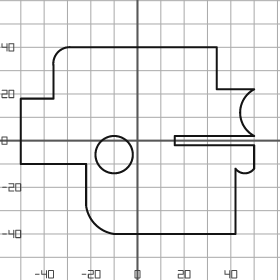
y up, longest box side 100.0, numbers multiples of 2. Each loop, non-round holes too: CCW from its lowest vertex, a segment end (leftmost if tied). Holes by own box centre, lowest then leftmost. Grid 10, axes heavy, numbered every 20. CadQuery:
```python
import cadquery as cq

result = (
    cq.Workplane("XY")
    .moveTo(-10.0, -40.0)
    .lineTo(42.0, -40.0)
    .lineTo(42.0, -12.0)
    .threePointArc((46.0, -14.0), (50.0, -12.0))
    .lineTo(50.0, -2.0)
    .lineTo(16.0, -2.0)
    .lineTo(16.0, 2.0)
    .lineTo(50.0, 2.0)
    .threePointArc((44.0, 12.0), (50.0, 22.0))
    .lineTo(34.0, 22.0)
    .lineTo(34.0, 40.0)
    .lineTo(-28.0, 40.0)
    .threePointArc((-34.0, 38.0), (-36.0, 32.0))
    .lineTo(-36.0, 18.0)
    .lineTo(-50.0, 18.0)
    .lineTo(-50.0, -10.0)
    .lineTo(-22.0, -10.0)
    .lineTo(-22.0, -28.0)
    .threePointArc((-18.0, -36.0), (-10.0, -40.0))
    .close()
    .moveTo(-10.0, -6.0)
    .circle(8.0)
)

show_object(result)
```